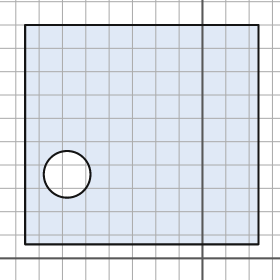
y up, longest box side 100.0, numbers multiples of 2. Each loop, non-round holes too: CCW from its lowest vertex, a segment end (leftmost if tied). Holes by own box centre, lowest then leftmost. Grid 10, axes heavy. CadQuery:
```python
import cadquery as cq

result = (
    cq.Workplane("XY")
    .moveTo(-76.0, 6.0)
    .lineTo(24.0, 6.0)
    .lineTo(24.0, 100.0)
    .lineTo(-76.0, 100.0)
    .close()
    .moveTo(-58.0, 36.0)
    .circle(10.0)
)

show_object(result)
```